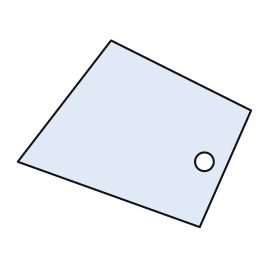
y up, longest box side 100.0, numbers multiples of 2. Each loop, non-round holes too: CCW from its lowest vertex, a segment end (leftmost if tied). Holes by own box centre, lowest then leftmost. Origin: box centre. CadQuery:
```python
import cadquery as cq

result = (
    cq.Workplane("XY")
    .moveTo(28.0, -40.0)
    .lineTo(50.0, 10.0)
    .lineTo(-10.0, 40.0)
    .lineTo(-50.0, -12.0)
    .close()
    .moveTo(30.0, -12.0)
    .circle(4.0)
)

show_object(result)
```